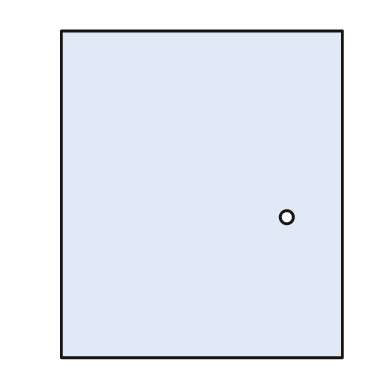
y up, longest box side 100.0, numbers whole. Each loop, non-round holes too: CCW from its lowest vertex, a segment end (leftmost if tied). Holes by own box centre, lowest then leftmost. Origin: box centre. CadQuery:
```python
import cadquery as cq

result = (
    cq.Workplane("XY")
    .moveTo(-43.0, -50.0)
    .lineTo(43.0, -50.0)
    .lineTo(43.0, 50.0)
    .lineTo(-43.0, 50.0)
    .close()
    .moveTo(26.0, -7.0)
    .circle(2.0)
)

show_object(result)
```